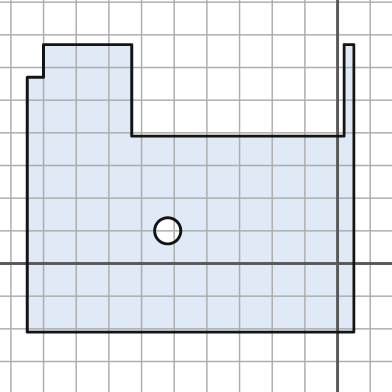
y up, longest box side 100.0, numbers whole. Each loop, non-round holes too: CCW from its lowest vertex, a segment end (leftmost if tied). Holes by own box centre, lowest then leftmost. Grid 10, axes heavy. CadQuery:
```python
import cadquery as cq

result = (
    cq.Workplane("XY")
    .moveTo(-95.0, -21.0)
    .lineTo(5.0, -21.0)
    .lineTo(5.0, 67.0)
    .lineTo(2.0, 67.0)
    .lineTo(2.0, 39.0)
    .lineTo(-63.0, 39.0)
    .lineTo(-63.0, 67.0)
    .lineTo(-90.0, 67.0)
    .lineTo(-90.0, 57.0)
    .lineTo(-95.0, 57.0)
    .close()
    .moveTo(-52.0, 10.0)
    .circle(4.0)
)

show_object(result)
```